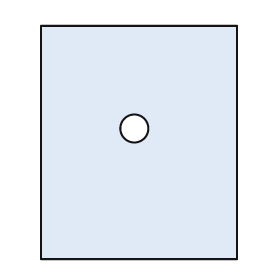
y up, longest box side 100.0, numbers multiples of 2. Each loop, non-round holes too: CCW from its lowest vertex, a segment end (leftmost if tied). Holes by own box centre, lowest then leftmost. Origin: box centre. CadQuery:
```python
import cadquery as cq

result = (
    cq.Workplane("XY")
    .moveTo(-42.0, -50.0)
    .lineTo(42.0, -50.0)
    .lineTo(42.0, 50.0)
    .lineTo(-42.0, 50.0)
    .close()
    .moveTo(-2.0, 6.0)
    .circle(6.0)
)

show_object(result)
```